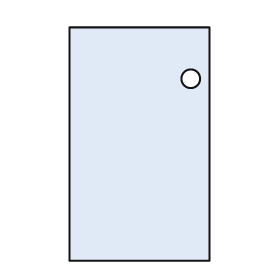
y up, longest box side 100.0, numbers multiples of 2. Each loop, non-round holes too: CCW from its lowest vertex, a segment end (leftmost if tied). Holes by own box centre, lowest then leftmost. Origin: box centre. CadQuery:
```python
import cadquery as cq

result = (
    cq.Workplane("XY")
    .moveTo(-30.0, -50.0)
    .lineTo(30.0, -50.0)
    .lineTo(30.0, 50.0)
    .lineTo(-30.0, 50.0)
    .close()
    .moveTo(22.0, 28.0)
    .circle(4.0)
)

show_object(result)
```